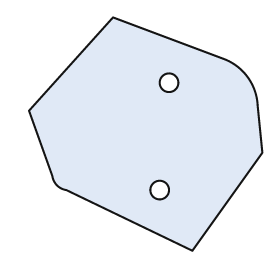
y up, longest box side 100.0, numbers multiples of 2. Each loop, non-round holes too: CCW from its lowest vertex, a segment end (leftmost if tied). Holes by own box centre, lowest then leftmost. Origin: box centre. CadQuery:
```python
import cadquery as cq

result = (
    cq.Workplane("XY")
    .moveTo(20.0, -50.0)
    .lineTo(50.0, -8.0)
    .lineTo(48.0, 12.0)
    .threePointArc((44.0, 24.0), (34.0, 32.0))
    .lineTo(-14.0, 50.0)
    .lineTo(-50.0, 10.0)
    .lineTo(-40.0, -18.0)
    .threePointArc((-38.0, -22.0), (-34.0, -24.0))
    .close()
    .moveTo(6.0, -24.0)
    .circle(4.0)
    .moveTo(10.0, 22.0)
    .circle(4.0)
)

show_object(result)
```